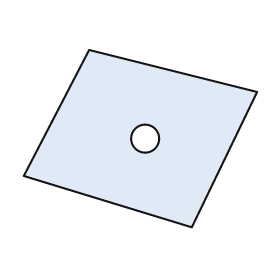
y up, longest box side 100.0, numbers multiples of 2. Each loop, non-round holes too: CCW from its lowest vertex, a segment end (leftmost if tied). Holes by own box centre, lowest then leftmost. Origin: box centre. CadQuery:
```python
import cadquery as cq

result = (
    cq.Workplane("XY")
    .moveTo(22.0, -38.0)
    .lineTo(50.0, 20.0)
    .lineTo(-22.0, 38.0)
    .lineTo(-50.0, -16.0)
    .close()
    .moveTo(2.0, 0.0)
    .circle(6.0)
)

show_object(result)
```